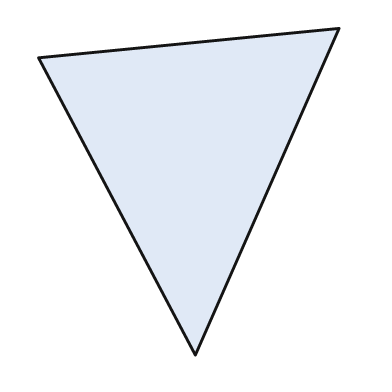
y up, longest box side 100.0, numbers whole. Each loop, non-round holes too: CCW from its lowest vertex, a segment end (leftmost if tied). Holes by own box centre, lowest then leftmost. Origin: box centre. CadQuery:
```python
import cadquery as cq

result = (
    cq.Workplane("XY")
    .moveTo(2.0, -50.0)
    .lineTo(46.0, 50.0)
    .lineTo(-46.0, 41.0)
    .close()
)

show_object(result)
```